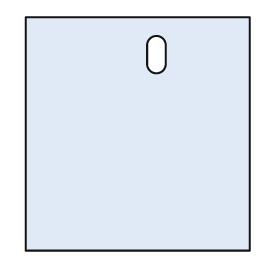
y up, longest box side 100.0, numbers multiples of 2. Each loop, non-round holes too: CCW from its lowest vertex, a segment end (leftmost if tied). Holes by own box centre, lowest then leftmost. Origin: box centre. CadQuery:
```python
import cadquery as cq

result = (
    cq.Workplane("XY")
    .moveTo(-48.0, -50.0)
    .lineTo(48.0, -50.0)
    .lineTo(48.0, 50.0)
    .lineTo(-48.0, 50.0)
    .close()
    .moveTo(4.0, 30.0)
    .threePointArc((8.0, 26.0), (12.0, 30.0))
    .lineTo(12.0, 38.0)
    .threePointArc((8.0, 42.0), (4.0, 38.0))
    .close()
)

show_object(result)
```